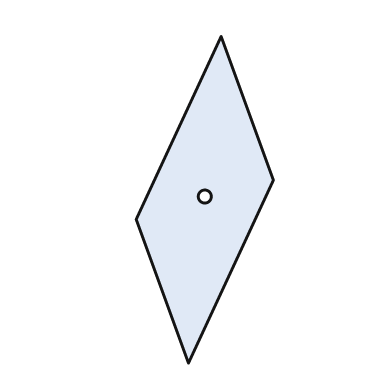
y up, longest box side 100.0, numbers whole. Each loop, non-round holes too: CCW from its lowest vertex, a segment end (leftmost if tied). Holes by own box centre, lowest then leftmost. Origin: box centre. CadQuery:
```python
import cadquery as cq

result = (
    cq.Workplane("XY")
    .moveTo(-5.0, -50.0)
    .lineTo(21.0, 6.0)
    .lineTo(5.0, 50.0)
    .lineTo(-21.0, -6.0)
    .close()
    .moveTo(0.0, 1.0)
    .circle(2.0)
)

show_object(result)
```